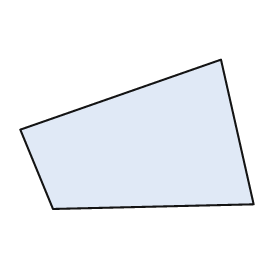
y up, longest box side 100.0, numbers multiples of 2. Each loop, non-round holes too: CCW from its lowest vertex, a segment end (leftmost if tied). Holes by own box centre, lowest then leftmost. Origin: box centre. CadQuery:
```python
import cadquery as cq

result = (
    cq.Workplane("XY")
    .moveTo(-36.0, -32.0)
    .lineTo(50.0, -30.0)
    .lineTo(36.0, 32.0)
    .lineTo(-50.0, 2.0)
    .close()
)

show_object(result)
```